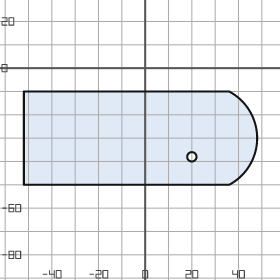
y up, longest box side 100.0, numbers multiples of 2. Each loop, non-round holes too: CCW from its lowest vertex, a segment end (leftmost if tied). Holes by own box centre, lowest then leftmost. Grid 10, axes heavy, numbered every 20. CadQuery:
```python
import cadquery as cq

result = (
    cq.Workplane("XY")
    .moveTo(-52.0, -50.0)
    .lineTo(36.0, -50.0)
    .threePointArc((48.0, -30.0), (36.0, -10.0))
    .lineTo(-52.0, -10.0)
    .close()
    .moveTo(20.0, -38.0)
    .circle(2.0)
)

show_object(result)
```